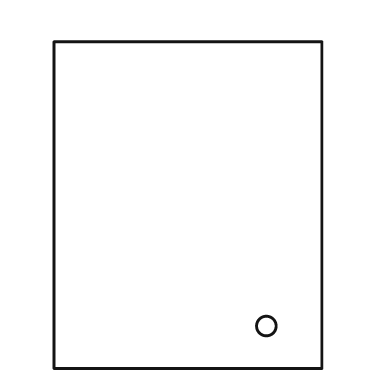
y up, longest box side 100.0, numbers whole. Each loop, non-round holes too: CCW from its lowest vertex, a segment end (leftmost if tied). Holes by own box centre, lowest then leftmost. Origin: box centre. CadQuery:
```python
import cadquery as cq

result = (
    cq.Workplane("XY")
    .moveTo(-41.0, -50.0)
    .lineTo(41.0, -50.0)
    .lineTo(41.0, 50.0)
    .lineTo(-41.0, 50.0)
    .close()
    .moveTo(24.0, -37.0)
    .circle(3.0)
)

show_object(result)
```